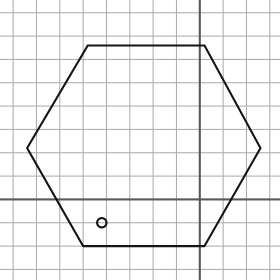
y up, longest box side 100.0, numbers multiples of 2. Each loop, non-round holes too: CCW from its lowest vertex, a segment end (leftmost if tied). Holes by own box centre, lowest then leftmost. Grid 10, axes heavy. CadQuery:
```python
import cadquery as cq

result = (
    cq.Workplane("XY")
    .moveTo(-50.0, -20.0)
    .lineTo(2.0, -20.0)
    .lineTo(26.0, 22.0)
    .lineTo(2.0, 66.0)
    .lineTo(-48.0, 66.0)
    .lineTo(-74.0, 22.0)
    .close()
    .moveTo(-42.0, -10.0)
    .circle(2.0)
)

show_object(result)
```